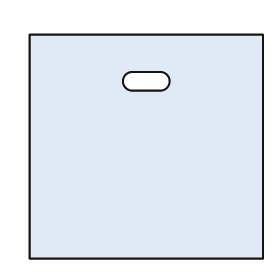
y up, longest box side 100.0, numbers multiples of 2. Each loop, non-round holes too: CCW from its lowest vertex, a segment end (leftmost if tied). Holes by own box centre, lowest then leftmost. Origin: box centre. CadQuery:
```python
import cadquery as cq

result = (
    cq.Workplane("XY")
    .moveTo(-50.0, -48.0)
    .lineTo(50.0, -48.0)
    .lineTo(50.0, 48.0)
    .lineTo(-50.0, 48.0)
    .close()
    .moveTo(-6.0, 24.0)
    .lineTo(6.0, 24.0)
    .threePointArc((10.0, 28.0), (6.0, 32.0))
    .lineTo(-6.0, 32.0)
    .threePointArc((-10.0, 28.0), (-6.0, 24.0))
    .close()
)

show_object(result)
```